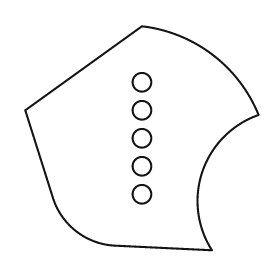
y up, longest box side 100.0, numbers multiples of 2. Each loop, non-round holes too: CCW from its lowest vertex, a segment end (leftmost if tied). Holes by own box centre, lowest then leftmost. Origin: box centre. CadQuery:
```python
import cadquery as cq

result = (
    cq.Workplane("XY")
    .moveTo(30.0, -48.0)
    .threePointArc((26.0, -14.0), (50.0, 10.0))
    .threePointArc((30.0, 36.0), (0.0, 48.0))
    .lineTo(-50.0, 12.0)
    .lineTo(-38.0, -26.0)
    .threePointArc((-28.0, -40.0), (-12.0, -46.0))
    .close()
    .moveTo(0.0, -24.0)
    .circle(4.0)
    .moveTo(0.0, -12.0)
    .circle(4.0)
    .moveTo(0.0, 0.0)
    .circle(4.0)
    .moveTo(0.0, 12.0)
    .circle(4.0)
    .moveTo(0.0, 24.0)
    .circle(4.0)
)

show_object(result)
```